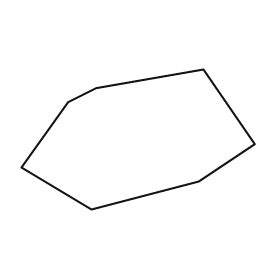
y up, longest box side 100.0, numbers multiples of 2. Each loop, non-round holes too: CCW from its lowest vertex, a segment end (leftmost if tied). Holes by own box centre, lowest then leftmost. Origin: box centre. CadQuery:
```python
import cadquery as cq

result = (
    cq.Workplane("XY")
    .moveTo(-20.0, -30.0)
    .lineTo(26.0, -18.0)
    .lineTo(50.0, -2.0)
    .lineTo(28.0, 30.0)
    .lineTo(-18.0, 22.0)
    .lineTo(-30.0, 16.0)
    .lineTo(-50.0, -12.0)
    .close()
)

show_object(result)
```